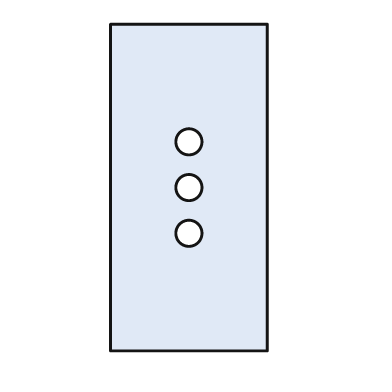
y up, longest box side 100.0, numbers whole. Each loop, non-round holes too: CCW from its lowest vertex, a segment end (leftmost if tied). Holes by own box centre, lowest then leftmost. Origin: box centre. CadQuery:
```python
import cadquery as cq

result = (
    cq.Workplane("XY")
    .moveTo(-24.0, -50.0)
    .lineTo(24.0, -50.0)
    .lineTo(24.0, 50.0)
    .lineTo(-24.0, 50.0)
    .close()
    .moveTo(0.0, -14.0)
    .circle(4.0)
    .moveTo(0.0, 0.0)
    .circle(4.0)
    .moveTo(0.0, 14.0)
    .circle(4.0)
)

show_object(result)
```